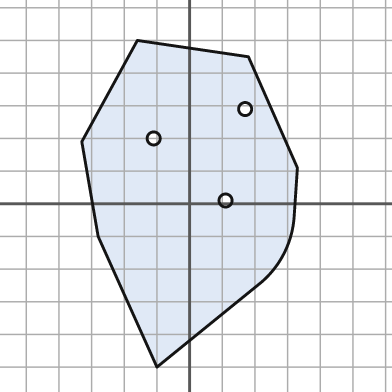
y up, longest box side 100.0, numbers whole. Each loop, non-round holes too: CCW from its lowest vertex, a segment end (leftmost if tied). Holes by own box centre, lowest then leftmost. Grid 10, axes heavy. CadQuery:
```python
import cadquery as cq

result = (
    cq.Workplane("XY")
    .moveTo(-10.0, -50.0)
    .lineTo(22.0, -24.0)
    .threePointArc((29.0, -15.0), (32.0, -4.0))
    .lineTo(33.0, 11.0)
    .lineTo(18.0, 45.0)
    .lineTo(-16.0, 50.0)
    .lineTo(-33.0, 19.0)
    .lineTo(-28.0, -10.0)
    .close()
    .moveTo(11.0, 1.0)
    .circle(2.0)
    .moveTo(-11.0, 20.0)
    .circle(2.0)
    .moveTo(17.0, 29.0)
    .circle(2.0)
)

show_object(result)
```